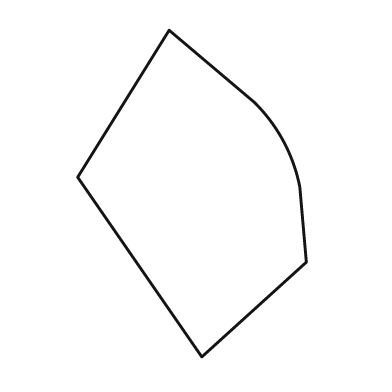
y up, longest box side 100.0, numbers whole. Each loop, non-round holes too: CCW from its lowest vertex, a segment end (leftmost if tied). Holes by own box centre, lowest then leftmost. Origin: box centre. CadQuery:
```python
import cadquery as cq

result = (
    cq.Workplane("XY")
    .moveTo(3.0, -50.0)
    .lineTo(35.0, -21.0)
    .lineTo(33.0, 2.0)
    .threePointArc((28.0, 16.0), (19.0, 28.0))
    .lineTo(-7.0, 50.0)
    .lineTo(-35.0, 5.0)
    .close()
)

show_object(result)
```